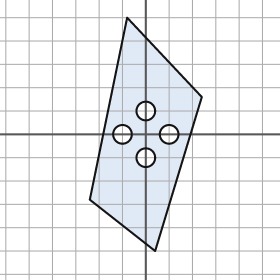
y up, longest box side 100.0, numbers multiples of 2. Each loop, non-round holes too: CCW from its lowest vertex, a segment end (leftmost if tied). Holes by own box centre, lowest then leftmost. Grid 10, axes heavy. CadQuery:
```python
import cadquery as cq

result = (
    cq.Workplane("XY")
    .moveTo(4.0, -50.0)
    .lineTo(24.0, 16.0)
    .lineTo(-8.0, 50.0)
    .lineTo(-24.0, -28.0)
    .close()
    .moveTo(0.0, -10.0)
    .circle(4.0)
    .moveTo(-10.0, 0.0)
    .circle(4.0)
    .moveTo(10.0, 0.0)
    .circle(4.0)
    .moveTo(0.0, 10.0)
    .circle(4.0)
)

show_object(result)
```